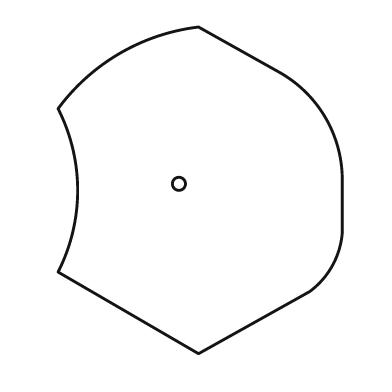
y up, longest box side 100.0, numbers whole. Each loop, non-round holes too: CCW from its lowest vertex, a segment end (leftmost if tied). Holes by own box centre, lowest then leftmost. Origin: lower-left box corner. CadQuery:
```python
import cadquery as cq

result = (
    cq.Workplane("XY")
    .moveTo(43.0, 0.0)
    .lineTo(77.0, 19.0)
    .threePointArc((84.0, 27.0), (87.0, 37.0))
    .lineTo(87.0, 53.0)
    .threePointArc((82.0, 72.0), (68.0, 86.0))
    .lineTo(43.0, 100.0)
    .threePointArc((19.0, 92.0), (0.0, 75.0))
    .threePointArc((6.0, 50.0), (0.0, 25.0))
    .close()
    .moveTo(37.0, 52.0)
    .circle(2.0)
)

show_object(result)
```